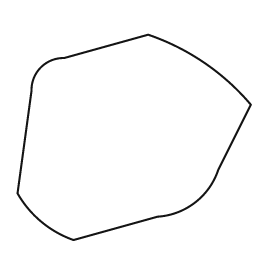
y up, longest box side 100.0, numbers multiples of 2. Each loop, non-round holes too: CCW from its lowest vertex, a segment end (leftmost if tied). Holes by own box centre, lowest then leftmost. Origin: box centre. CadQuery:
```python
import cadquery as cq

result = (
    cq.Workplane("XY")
    .moveTo(-26.0, -44.0)
    .lineTo(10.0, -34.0)
    .threePointArc((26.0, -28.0), (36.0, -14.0))
    .lineTo(50.0, 14.0)
    .threePointArc((30.0, 32.0), (6.0, 44.0))
    .lineTo(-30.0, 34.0)
    .threePointArc((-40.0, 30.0), (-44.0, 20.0))
    .lineTo(-50.0, -24.0)
    .threePointArc((-40.0, -36.0), (-26.0, -44.0))
    .close()
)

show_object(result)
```